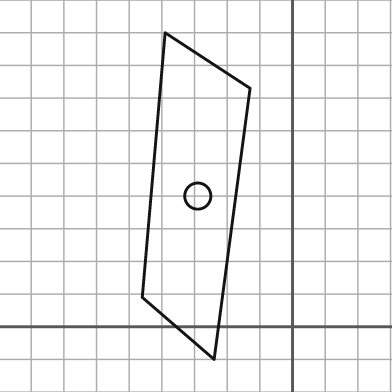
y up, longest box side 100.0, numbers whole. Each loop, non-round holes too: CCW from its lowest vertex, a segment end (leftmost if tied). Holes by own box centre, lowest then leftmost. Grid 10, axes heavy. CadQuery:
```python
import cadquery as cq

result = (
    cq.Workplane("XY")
    .moveTo(-24.0, -10.0)
    .lineTo(-13.0, 73.0)
    .lineTo(-39.0, 90.0)
    .lineTo(-46.0, 9.0)
    .close()
    .moveTo(-29.0, 40.0)
    .circle(4.0)
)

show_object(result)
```